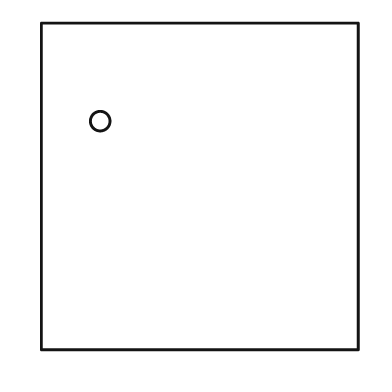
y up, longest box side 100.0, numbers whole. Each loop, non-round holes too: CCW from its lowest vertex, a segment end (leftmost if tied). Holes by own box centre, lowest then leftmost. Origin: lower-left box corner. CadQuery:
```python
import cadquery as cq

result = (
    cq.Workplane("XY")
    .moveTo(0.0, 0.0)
    .lineTo(97.0, 0.0)
    .lineTo(97.0, 100.0)
    .lineTo(0.0, 100.0)
    .close()
    .moveTo(18.0, 70.0)
    .circle(3.0)
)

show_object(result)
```